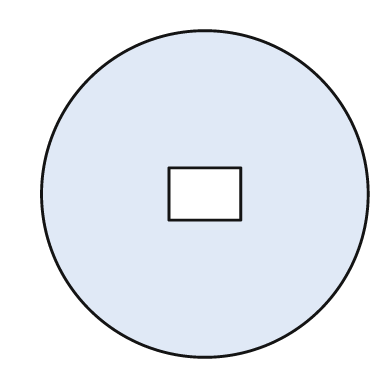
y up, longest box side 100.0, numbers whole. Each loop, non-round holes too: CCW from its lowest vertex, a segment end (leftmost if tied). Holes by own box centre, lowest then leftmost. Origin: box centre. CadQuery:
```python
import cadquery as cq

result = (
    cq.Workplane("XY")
    .moveTo(0.0, 0.0)
    .circle(50.0)
    .moveTo(-11.0, -8.0)
    .lineTo(11.0, -8.0)
    .lineTo(11.0, 8.0)
    .lineTo(-11.0, 8.0)
    .close()
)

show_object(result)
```